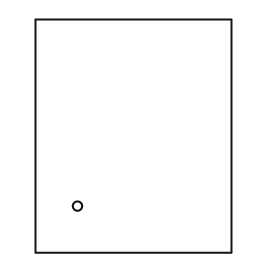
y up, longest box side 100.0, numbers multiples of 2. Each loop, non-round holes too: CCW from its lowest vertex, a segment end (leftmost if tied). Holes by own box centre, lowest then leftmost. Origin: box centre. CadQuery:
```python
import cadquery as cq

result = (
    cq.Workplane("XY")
    .moveTo(-42.0, -50.0)
    .lineTo(42.0, -50.0)
    .lineTo(42.0, 50.0)
    .lineTo(-42.0, 50.0)
    .close()
    .moveTo(-24.0, -30.0)
    .circle(2.0)
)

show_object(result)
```